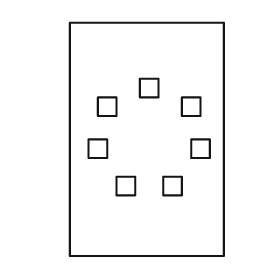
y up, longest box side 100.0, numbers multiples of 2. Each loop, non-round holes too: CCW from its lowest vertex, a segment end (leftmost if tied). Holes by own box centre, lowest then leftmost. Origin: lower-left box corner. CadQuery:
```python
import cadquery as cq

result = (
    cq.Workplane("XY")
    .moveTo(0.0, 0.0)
    .lineTo(66.0, 0.0)
    .lineTo(66.0, 100.0)
    .lineTo(0.0, 100.0)
    .close()
    .moveTo(20.0, 26.0)
    .lineTo(28.0, 26.0)
    .lineTo(28.0, 34.0)
    .lineTo(20.0, 34.0)
    .close()
    .moveTo(40.0, 26.0)
    .lineTo(48.0, 26.0)
    .lineTo(48.0, 34.0)
    .lineTo(40.0, 34.0)
    .close()
    .moveTo(8.0, 42.0)
    .lineTo(16.0, 42.0)
    .lineTo(16.0, 50.0)
    .lineTo(8.0, 50.0)
    .close()
    .moveTo(52.0, 42.0)
    .lineTo(60.0, 42.0)
    .lineTo(60.0, 50.0)
    .lineTo(52.0, 50.0)
    .close()
    .moveTo(12.0, 60.0)
    .lineTo(20.0, 60.0)
    .lineTo(20.0, 68.0)
    .lineTo(12.0, 68.0)
    .close()
    .moveTo(48.0, 60.0)
    .lineTo(56.0, 60.0)
    .lineTo(56.0, 68.0)
    .lineTo(48.0, 68.0)
    .close()
    .moveTo(30.0, 68.0)
    .lineTo(38.0, 68.0)
    .lineTo(38.0, 76.0)
    .lineTo(30.0, 76.0)
    .close()
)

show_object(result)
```